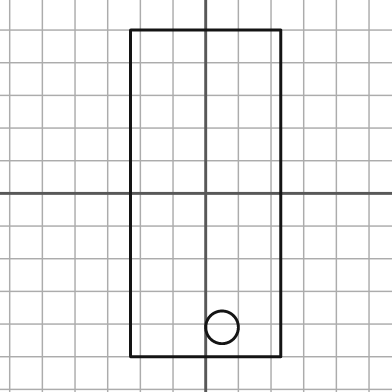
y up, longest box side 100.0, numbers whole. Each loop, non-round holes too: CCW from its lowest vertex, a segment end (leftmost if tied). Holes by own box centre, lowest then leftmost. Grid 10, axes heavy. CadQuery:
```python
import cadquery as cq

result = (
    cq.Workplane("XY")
    .moveTo(-23.0, -50.0)
    .lineTo(23.0, -50.0)
    .lineTo(23.0, 50.0)
    .lineTo(-23.0, 50.0)
    .close()
    .moveTo(5.0, -41.0)
    .circle(5.0)
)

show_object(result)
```